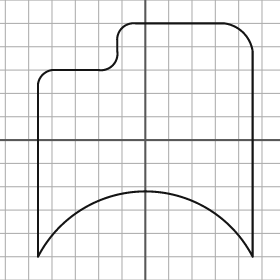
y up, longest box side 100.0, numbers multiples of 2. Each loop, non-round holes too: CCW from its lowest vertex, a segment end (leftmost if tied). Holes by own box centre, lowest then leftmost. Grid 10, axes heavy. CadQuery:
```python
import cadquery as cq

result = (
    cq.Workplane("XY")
    .moveTo(-46.0, -50.0)
    .threePointArc((0.0, -22.0), (46.0, -50.0))
    .lineTo(46.0, 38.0)
    .threePointArc((42.0, 46.0), (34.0, 50.0))
    .lineTo(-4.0, 50.0)
    .threePointArc((-10.0, 48.0), (-12.0, 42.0))
    .lineTo(-12.0, 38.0)
    .threePointArc((-14.0, 32.0), (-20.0, 30.0))
    .lineTo(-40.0, 30.0)
    .threePointArc((-44.0, 28.0), (-46.0, 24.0))
    .close()
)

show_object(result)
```